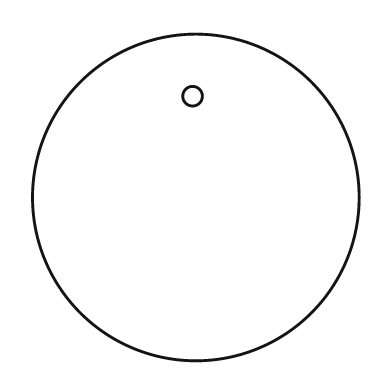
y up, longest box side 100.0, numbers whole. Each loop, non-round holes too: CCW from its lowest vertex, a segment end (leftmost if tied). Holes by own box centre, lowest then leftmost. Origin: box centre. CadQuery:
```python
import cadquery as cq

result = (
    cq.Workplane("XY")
    .moveTo(0.0, 0.0)
    .circle(50.0)
    .moveTo(-1.0, 31.0)
    .circle(3.0)
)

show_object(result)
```